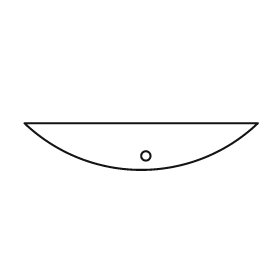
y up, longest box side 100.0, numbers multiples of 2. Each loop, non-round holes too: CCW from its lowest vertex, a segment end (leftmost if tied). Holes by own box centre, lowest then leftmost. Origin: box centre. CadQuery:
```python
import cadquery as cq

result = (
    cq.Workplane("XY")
    .moveTo(-50.0, 10.0)
    .threePointArc((0.0, -10.0), (50.0, 10.0))
    .close()
    .moveTo(2.0, -4.0)
    .circle(2.0)
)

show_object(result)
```